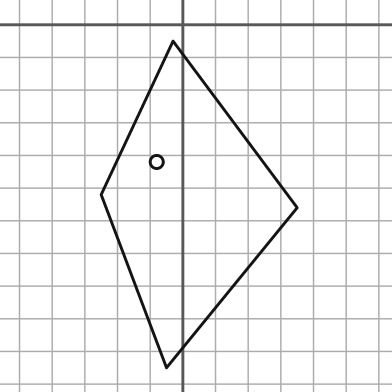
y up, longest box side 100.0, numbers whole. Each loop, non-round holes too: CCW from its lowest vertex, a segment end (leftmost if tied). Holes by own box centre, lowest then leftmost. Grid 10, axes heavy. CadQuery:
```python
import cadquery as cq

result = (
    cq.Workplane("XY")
    .moveTo(-5.0, -105.0)
    .lineTo(35.0, -56.0)
    .lineTo(-3.0, -5.0)
    .lineTo(-25.0, -52.0)
    .close()
    .moveTo(-8.0, -42.0)
    .circle(2.0)
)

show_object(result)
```